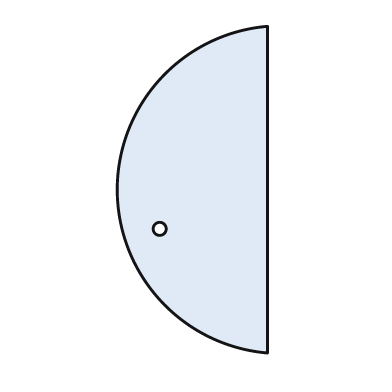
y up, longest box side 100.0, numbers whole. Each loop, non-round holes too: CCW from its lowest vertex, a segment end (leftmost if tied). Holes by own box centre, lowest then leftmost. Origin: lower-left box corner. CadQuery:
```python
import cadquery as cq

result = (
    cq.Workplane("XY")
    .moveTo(46.0, 0.0)
    .lineTo(46.0, 100.0)
    .threePointArc((0.0, 50.0), (46.0, 0.0))
    .close()
    .moveTo(13.0, 38.0)
    .circle(2.0)
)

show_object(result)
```